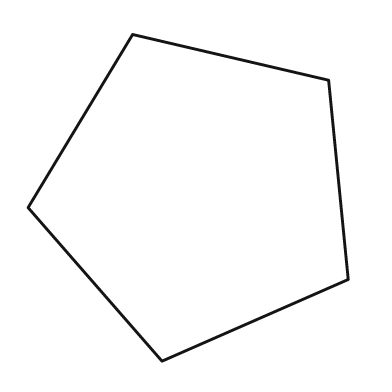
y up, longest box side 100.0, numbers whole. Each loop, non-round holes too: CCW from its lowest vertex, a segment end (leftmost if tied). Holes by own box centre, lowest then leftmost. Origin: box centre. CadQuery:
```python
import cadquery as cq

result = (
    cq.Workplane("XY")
    .moveTo(-8.0, -50.0)
    .lineTo(49.0, -25.0)
    .lineTo(43.0, 36.0)
    .lineTo(-17.0, 50.0)
    .lineTo(-49.0, -3.0)
    .close()
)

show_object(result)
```